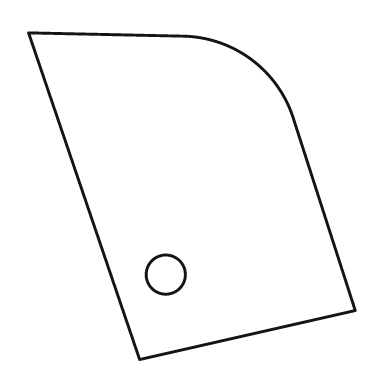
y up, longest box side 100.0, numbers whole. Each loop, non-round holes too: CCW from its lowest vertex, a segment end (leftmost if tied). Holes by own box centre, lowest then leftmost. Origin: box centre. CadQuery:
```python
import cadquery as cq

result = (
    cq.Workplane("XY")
    .moveTo(-16.0, -50.0)
    .lineTo(50.0, -35.0)
    .lineTo(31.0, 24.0)
    .threePointArc((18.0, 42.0), (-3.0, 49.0))
    .lineTo(-50.0, 50.0)
    .close()
    .moveTo(-8.0, -24.0)
    .circle(6.0)
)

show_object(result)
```